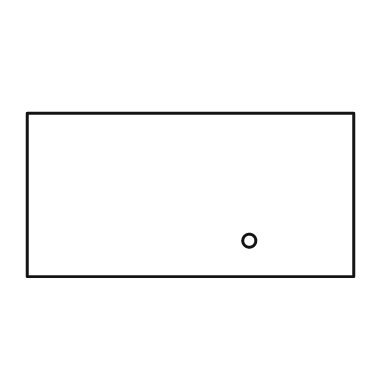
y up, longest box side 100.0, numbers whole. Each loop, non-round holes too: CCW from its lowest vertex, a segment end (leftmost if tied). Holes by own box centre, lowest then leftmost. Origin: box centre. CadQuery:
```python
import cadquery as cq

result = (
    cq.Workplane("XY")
    .moveTo(-50.0, -25.0)
    .lineTo(50.0, -25.0)
    .lineTo(50.0, 25.0)
    .lineTo(-50.0, 25.0)
    .close()
    .moveTo(18.0, -14.0)
    .circle(2.0)
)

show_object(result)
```